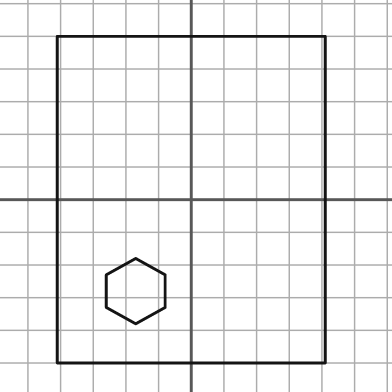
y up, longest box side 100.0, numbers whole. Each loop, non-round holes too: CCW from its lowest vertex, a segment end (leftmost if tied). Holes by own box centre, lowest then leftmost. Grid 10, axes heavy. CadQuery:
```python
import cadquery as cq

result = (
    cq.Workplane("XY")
    .moveTo(-41.0, -50.0)
    .lineTo(41.0, -50.0)
    .lineTo(41.0, 50.0)
    .lineTo(-41.0, 50.0)
    .close()
    .moveTo(-17.0, -38.0)
    .lineTo(-8.0, -33.0)
    .lineTo(-8.0, -23.0)
    .lineTo(-17.0, -18.0)
    .lineTo(-26.0, -23.0)
    .lineTo(-26.0, -33.0)
    .close()
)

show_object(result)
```